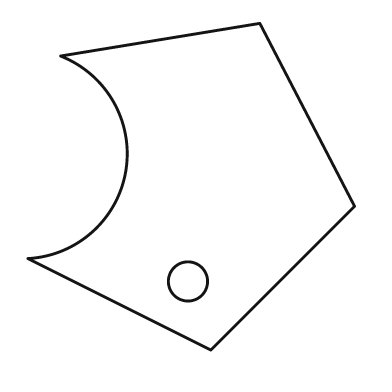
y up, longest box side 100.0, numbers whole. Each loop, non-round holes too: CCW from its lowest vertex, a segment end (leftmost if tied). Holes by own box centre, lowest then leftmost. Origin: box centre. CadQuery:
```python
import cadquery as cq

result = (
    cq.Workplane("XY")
    .moveTo(6.0, -50.0)
    .lineTo(50.0, -6.0)
    .lineTo(21.0, 50.0)
    .lineTo(-40.0, 40.0)
    .threePointArc((-20.0, 5.0), (-50.0, -22.0))
    .close()
    .moveTo(-1.0, -29.0)
    .circle(6.0)
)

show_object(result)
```